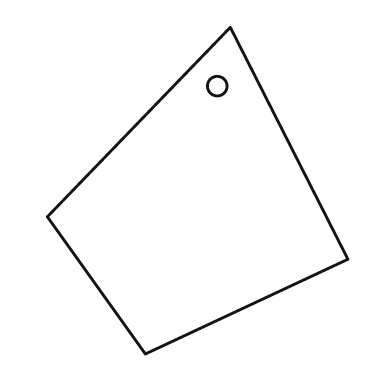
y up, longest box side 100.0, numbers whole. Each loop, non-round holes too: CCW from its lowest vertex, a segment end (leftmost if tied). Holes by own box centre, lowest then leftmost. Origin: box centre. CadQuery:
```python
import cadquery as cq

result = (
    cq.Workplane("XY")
    .moveTo(-16.0, -50.0)
    .lineTo(46.0, -21.0)
    .lineTo(10.0, 50.0)
    .lineTo(-46.0, -8.0)
    .close()
    .moveTo(6.0, 32.0)
    .circle(3.0)
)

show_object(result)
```